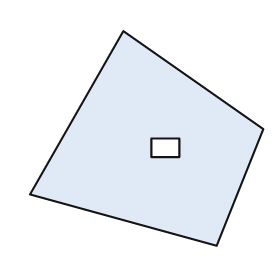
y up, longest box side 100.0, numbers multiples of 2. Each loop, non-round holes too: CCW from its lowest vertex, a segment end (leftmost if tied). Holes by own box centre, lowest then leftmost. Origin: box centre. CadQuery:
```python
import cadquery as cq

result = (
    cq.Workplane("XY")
    .moveTo(30.0, -46.0)
    .lineTo(50.0, 4.0)
    .lineTo(-10.0, 46.0)
    .lineTo(-50.0, -24.0)
    .close()
    .moveTo(2.0, -8.0)
    .lineTo(14.0, -8.0)
    .lineTo(14.0, 0.0)
    .lineTo(2.0, 0.0)
    .close()
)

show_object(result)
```